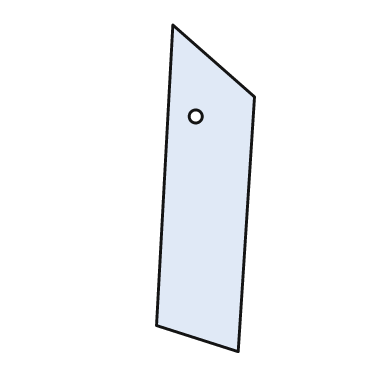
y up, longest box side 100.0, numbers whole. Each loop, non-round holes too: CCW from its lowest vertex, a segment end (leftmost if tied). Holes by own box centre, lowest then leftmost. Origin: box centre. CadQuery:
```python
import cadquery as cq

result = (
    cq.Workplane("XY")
    .moveTo(10.0, -50.0)
    .lineTo(15.0, 28.0)
    .lineTo(-10.0, 50.0)
    .lineTo(-15.0, -42.0)
    .close()
    .moveTo(-3.0, 22.0)
    .circle(2.0)
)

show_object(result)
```